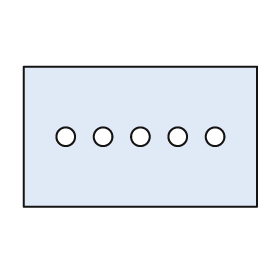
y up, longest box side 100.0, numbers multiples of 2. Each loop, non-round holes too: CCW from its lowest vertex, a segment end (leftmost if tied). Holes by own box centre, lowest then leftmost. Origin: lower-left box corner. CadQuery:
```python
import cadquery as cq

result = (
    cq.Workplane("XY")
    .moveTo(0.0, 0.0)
    .lineTo(100.0, 0.0)
    .lineTo(100.0, 60.0)
    .lineTo(0.0, 60.0)
    .close()
    .moveTo(18.0, 30.0)
    .circle(4.0)
    .moveTo(34.0, 30.0)
    .circle(4.0)
    .moveTo(50.0, 30.0)
    .circle(4.0)
    .moveTo(66.0, 30.0)
    .circle(4.0)
    .moveTo(82.0, 30.0)
    .circle(4.0)
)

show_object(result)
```